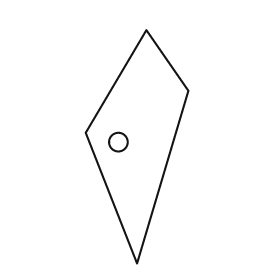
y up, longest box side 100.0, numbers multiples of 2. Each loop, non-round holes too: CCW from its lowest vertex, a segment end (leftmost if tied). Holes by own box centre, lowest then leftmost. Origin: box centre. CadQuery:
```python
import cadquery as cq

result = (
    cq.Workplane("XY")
    .moveTo(0.0, -50.0)
    .lineTo(22.0, 24.0)
    .lineTo(4.0, 50.0)
    .lineTo(-22.0, 6.0)
    .close()
    .moveTo(-8.0, 2.0)
    .circle(4.0)
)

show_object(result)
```